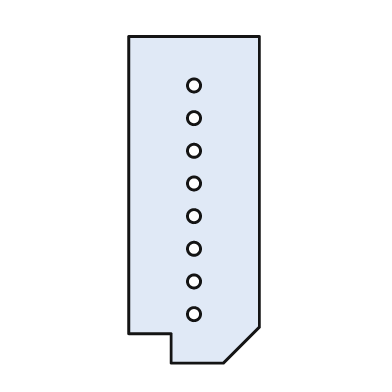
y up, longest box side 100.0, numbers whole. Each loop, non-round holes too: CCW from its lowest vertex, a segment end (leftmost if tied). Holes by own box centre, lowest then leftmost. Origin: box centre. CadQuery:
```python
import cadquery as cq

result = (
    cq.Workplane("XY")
    .moveTo(-7.0, -50.0)
    .lineTo(9.0, -50.0)
    .lineTo(20.0, -39.0)
    .lineTo(20.0, 50.0)
    .lineTo(-20.0, 50.0)
    .lineTo(-20.0, -41.0)
    .lineTo(-7.0, -41.0)
    .close()
    .moveTo(0.0, -35.0)
    .circle(2.0)
    .moveTo(0.0, -25.0)
    .circle(2.0)
    .moveTo(0.0, -15.0)
    .circle(2.0)
    .moveTo(0.0, -5.0)
    .circle(2.0)
    .moveTo(0.0, 5.0)
    .circle(2.0)
    .moveTo(0.0, 15.0)
    .circle(2.0)
    .moveTo(0.0, 25.0)
    .circle(2.0)
    .moveTo(0.0, 35.0)
    .circle(2.0)
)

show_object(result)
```